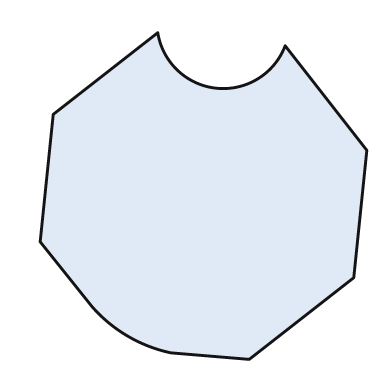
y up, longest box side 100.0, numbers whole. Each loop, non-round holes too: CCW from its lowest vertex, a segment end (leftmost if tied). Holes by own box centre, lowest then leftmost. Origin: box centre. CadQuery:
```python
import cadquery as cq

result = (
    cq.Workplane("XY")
    .moveTo(14.0, -50.0)
    .lineTo(46.0, -25.0)
    .lineTo(50.0, 14.0)
    .lineTo(25.0, 46.0)
    .threePointArc((4.0, 33.0), (-14.0, 50.0))
    .lineTo(-46.0, 25.0)
    .lineTo(-50.0, -14.0)
    .lineTo(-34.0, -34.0)
    .threePointArc((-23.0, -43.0), (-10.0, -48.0))
    .close()
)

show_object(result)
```